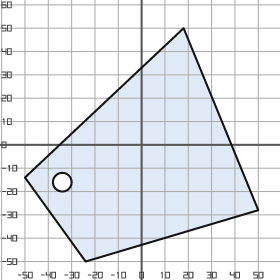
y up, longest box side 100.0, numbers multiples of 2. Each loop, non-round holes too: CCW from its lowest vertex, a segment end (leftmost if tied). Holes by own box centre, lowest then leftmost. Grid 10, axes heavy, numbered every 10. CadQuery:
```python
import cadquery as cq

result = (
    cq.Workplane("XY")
    .moveTo(-24.0, -50.0)
    .lineTo(50.0, -28.0)
    .lineTo(18.0, 50.0)
    .lineTo(-50.0, -14.0)
    .close()
    .moveTo(-34.0, -16.0)
    .circle(4.0)
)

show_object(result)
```